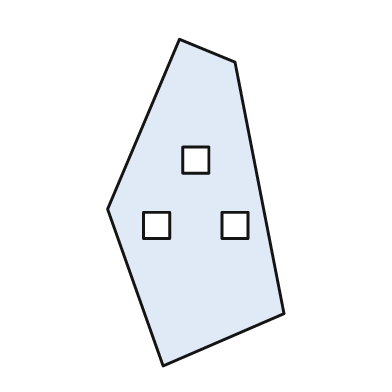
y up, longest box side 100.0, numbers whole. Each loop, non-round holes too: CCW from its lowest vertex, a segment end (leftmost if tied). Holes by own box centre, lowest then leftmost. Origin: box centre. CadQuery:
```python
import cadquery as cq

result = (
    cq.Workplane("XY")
    .moveTo(-10.0, -50.0)
    .lineTo(27.0, -34.0)
    .lineTo(12.0, 43.0)
    .lineTo(-5.0, 50.0)
    .lineTo(-27.0, -2.0)
    .close()
    .moveTo(-16.0, -11.0)
    .lineTo(-8.0, -11.0)
    .lineTo(-8.0, -3.0)
    .lineTo(-16.0, -3.0)
    .close()
    .moveTo(8.0, -11.0)
    .lineTo(16.0, -11.0)
    .lineTo(16.0, -3.0)
    .lineTo(8.0, -3.0)
    .close()
    .moveTo(-4.0, 9.0)
    .lineTo(4.0, 9.0)
    .lineTo(4.0, 17.0)
    .lineTo(-4.0, 17.0)
    .close()
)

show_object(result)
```